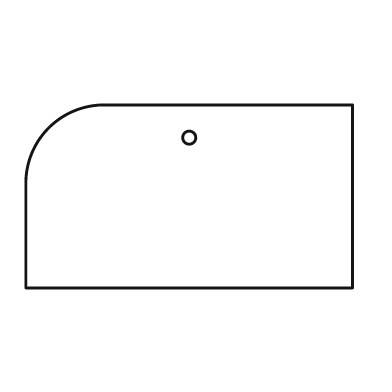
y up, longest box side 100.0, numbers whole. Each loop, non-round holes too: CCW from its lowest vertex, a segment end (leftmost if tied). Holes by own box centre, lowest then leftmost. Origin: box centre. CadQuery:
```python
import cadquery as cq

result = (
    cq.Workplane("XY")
    .moveTo(-50.0, -28.0)
    .lineTo(50.0, -28.0)
    .lineTo(50.0, 28.0)
    .lineTo(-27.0, 28.0)
    .threePointArc((-43.0, 21.0), (-50.0, 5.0))
    .close()
    .moveTo(0.0, 18.0)
    .circle(2.0)
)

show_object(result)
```